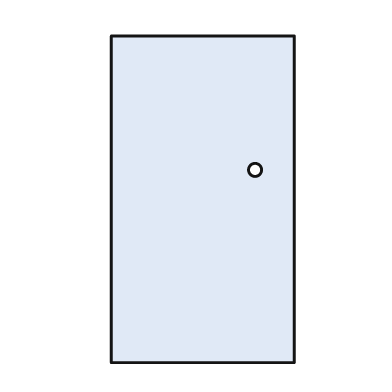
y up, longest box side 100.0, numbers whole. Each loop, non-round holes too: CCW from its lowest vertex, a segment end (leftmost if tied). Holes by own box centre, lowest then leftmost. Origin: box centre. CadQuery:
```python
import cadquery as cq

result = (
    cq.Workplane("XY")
    .moveTo(-28.0, -50.0)
    .lineTo(28.0, -50.0)
    .lineTo(28.0, 50.0)
    .lineTo(-28.0, 50.0)
    .close()
    .moveTo(16.0, 9.0)
    .circle(2.0)
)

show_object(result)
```